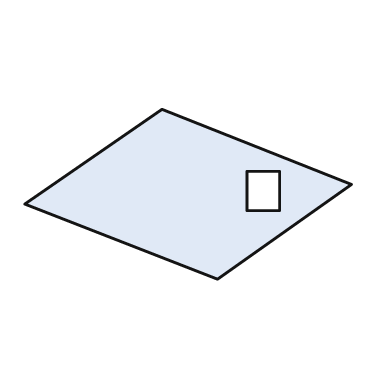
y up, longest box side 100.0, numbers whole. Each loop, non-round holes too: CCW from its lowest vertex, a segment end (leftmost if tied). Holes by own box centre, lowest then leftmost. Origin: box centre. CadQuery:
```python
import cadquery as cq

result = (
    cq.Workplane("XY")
    .moveTo(9.0, -26.0)
    .lineTo(50.0, 3.0)
    .lineTo(-8.0, 26.0)
    .lineTo(-50.0, -3.0)
    .close()
    .moveTo(18.0, -5.0)
    .lineTo(28.0, -5.0)
    .lineTo(28.0, 7.0)
    .lineTo(18.0, 7.0)
    .close()
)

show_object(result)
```